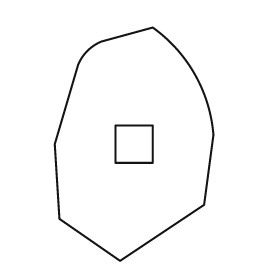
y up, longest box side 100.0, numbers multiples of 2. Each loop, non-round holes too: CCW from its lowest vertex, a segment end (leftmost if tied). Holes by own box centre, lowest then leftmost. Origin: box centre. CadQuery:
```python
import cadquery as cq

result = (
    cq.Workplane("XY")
    .moveTo(-6.0, -50.0)
    .lineTo(30.0, -26.0)
    .lineTo(34.0, 4.0)
    .threePointArc((26.0, 30.0), (8.0, 50.0))
    .lineTo(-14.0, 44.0)
    .threePointArc((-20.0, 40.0), (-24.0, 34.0))
    .lineTo(-34.0, 0.0)
    .lineTo(-32.0, -32.0)
    .close()
    .moveTo(-8.0, -8.0)
    .lineTo(8.0, -8.0)
    .lineTo(8.0, 8.0)
    .lineTo(-8.0, 8.0)
    .close()
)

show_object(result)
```